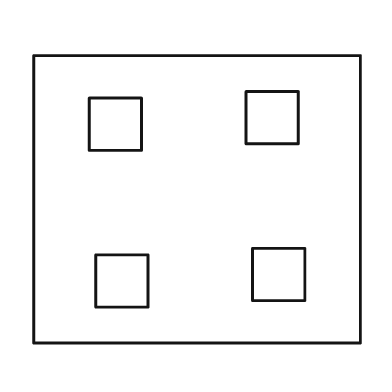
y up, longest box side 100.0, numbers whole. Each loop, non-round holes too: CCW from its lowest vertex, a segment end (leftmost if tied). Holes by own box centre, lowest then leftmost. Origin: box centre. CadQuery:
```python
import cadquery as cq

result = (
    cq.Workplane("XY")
    .moveTo(-50.0, -44.0)
    .lineTo(50.0, -44.0)
    .lineTo(50.0, 44.0)
    .lineTo(-50.0, 44.0)
    .close()
    .moveTo(-31.0, -33.0)
    .lineTo(-15.0, -33.0)
    .lineTo(-15.0, -17.0)
    .lineTo(-31.0, -17.0)
    .close()
    .moveTo(17.0, -31.0)
    .lineTo(33.0, -31.0)
    .lineTo(33.0, -15.0)
    .lineTo(17.0, -15.0)
    .close()
    .moveTo(-33.0, 15.0)
    .lineTo(-17.0, 15.0)
    .lineTo(-17.0, 31.0)
    .lineTo(-33.0, 31.0)
    .close()
    .moveTo(15.0, 17.0)
    .lineTo(31.0, 17.0)
    .lineTo(31.0, 33.0)
    .lineTo(15.0, 33.0)
    .close()
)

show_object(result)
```